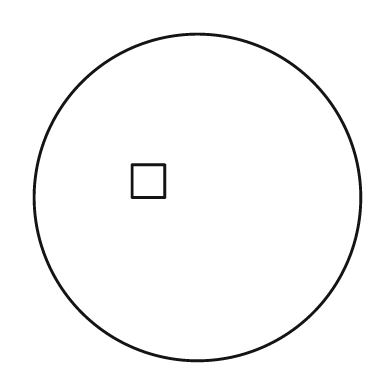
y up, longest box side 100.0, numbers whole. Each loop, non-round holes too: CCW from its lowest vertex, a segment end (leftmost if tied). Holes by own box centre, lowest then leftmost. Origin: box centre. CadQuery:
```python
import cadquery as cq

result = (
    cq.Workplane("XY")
    .moveTo(0.0, 0.0)
    .circle(50.0)
    .moveTo(-20.0, 0.0)
    .lineTo(-10.0, 0.0)
    .lineTo(-10.0, 10.0)
    .lineTo(-20.0, 10.0)
    .close()
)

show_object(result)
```